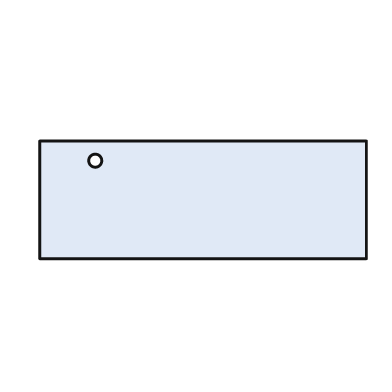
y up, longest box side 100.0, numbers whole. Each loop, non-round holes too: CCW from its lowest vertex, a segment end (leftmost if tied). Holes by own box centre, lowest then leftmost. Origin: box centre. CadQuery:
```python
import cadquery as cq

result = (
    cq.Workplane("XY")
    .moveTo(-50.0, -18.0)
    .lineTo(50.0, -18.0)
    .lineTo(50.0, 18.0)
    .lineTo(-50.0, 18.0)
    .close()
    .moveTo(-33.0, 12.0)
    .circle(2.0)
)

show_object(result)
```